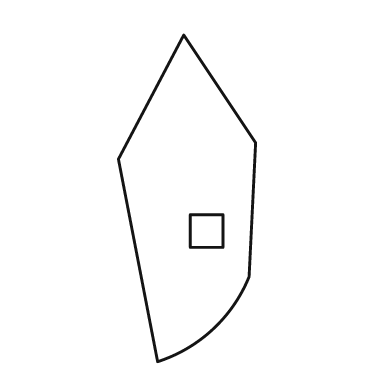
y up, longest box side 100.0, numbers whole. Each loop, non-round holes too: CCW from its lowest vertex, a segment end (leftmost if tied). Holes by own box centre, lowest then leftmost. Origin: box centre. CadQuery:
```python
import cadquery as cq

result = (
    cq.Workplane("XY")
    .moveTo(-9.0, -50.0)
    .threePointArc((8.0, -40.0), (19.0, -24.0))
    .lineTo(21.0, 17.0)
    .lineTo(-1.0, 50.0)
    .lineTo(-21.0, 12.0)
    .close()
    .moveTo(1.0, -15.0)
    .lineTo(11.0, -15.0)
    .lineTo(11.0, -5.0)
    .lineTo(1.0, -5.0)
    .close()
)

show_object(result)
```